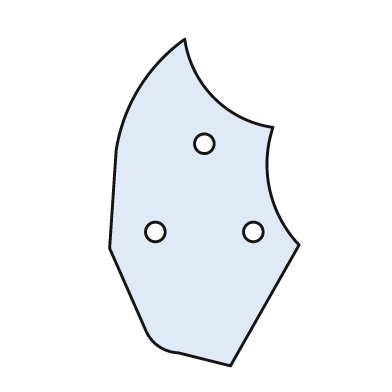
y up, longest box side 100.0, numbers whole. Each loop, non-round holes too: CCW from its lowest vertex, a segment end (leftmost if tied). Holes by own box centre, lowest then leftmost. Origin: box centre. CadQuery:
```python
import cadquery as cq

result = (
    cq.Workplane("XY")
    .moveTo(8.0, -50.0)
    .lineTo(29.0, -13.0)
    .threePointArc((20.0, 4.0), (21.0, 23.0))
    .threePointArc((3.0, 32.0), (-6.0, 50.0))
    .threePointArc((-20.0, 35.0), (-27.0, 16.0))
    .lineTo(-29.0, -14.0)
    .lineTo(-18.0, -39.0)
    .threePointArc((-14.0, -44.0), (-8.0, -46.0))
    .close()
    .moveTo(-15.0, -9.0)
    .circle(3.0)
    .moveTo(15.0, -9.0)
    .circle(3.0)
    .moveTo(0.0, 18.0)
    .circle(3.0)
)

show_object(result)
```